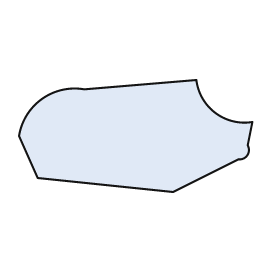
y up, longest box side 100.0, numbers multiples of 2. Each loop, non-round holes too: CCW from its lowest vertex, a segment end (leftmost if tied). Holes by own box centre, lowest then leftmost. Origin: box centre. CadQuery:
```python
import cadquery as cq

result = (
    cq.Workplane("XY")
    .moveTo(16.0, -24.0)
    .lineTo(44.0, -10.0)
    .threePointArc((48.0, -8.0), (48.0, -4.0))
    .lineTo(50.0, 6.0)
    .threePointArc((34.0, 10.0), (26.0, 24.0))
    .lineTo(-22.0, 20.0)
    .threePointArc((-40.0, 16.0), (-50.0, 0.0))
    .lineTo(-42.0, -18.0)
    .close()
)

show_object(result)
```